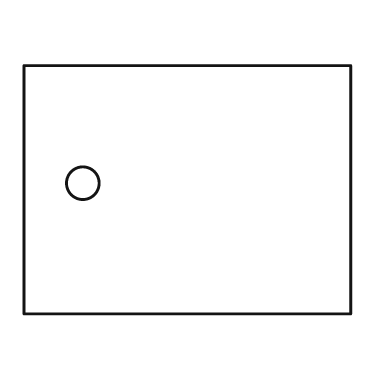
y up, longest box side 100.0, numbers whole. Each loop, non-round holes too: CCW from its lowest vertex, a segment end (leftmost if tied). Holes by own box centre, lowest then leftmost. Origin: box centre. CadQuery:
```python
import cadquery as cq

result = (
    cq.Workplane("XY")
    .moveTo(-50.0, -38.0)
    .lineTo(50.0, -38.0)
    .lineTo(50.0, 38.0)
    .lineTo(-50.0, 38.0)
    .close()
    .moveTo(-32.0, 2.0)
    .circle(5.0)
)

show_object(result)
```